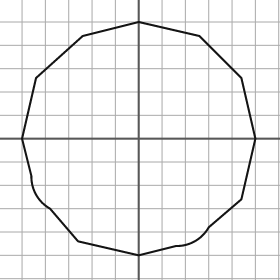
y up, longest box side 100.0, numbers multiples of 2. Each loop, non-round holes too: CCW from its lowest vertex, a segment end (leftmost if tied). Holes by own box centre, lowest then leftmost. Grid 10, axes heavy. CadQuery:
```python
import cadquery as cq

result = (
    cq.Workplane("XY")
    .moveTo(0.0, -50.0)
    .lineTo(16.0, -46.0)
    .threePointArc((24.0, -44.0), (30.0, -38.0))
    .lineTo(44.0, -26.0)
    .lineTo(50.0, 0.0)
    .lineTo(44.0, 26.0)
    .lineTo(26.0, 44.0)
    .lineTo(0.0, 50.0)
    .lineTo(-24.0, 44.0)
    .lineTo(-44.0, 26.0)
    .lineTo(-50.0, 0.0)
    .lineTo(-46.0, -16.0)
    .threePointArc((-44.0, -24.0), (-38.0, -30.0))
    .lineTo(-26.0, -44.0)
    .close()
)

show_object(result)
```